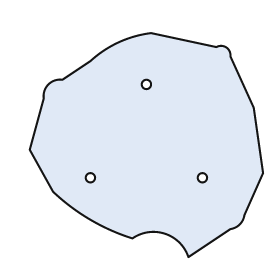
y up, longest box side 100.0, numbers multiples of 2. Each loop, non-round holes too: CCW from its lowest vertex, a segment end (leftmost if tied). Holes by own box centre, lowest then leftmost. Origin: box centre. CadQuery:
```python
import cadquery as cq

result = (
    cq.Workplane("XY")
    .moveTo(18.0, -48.0)
    .lineTo(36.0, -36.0)
    .threePointArc((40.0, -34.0), (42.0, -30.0))
    .lineTo(50.0, -12.0)
    .lineTo(46.0, 16.0)
    .lineTo(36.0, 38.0)
    .threePointArc((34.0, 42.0), (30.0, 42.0))
    .lineTo(2.0, 48.0)
    .threePointArc((-12.0, 44.0), (-24.0, 36.0))
    .lineTo(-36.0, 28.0)
    .threePointArc((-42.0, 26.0), (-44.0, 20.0))
    .lineTo(-50.0, -2.0)
    .lineTo(-40.0, -20.0)
    .threePointArc((-24.0, -32.0), (-6.0, -40.0))
    .threePointArc((8.0, -38.0), (18.0, -48.0))
    .close()
    .moveTo(-24.0, -14.0)
    .circle(2.0)
    .moveTo(24.0, -14.0)
    .circle(2.0)
    .moveTo(0.0, 26.0)
    .circle(2.0)
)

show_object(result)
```